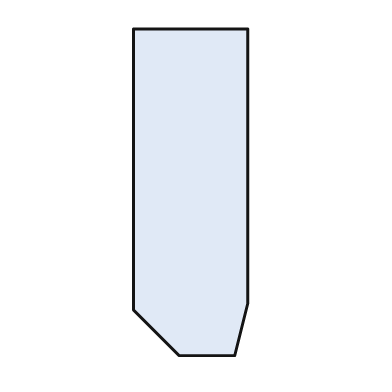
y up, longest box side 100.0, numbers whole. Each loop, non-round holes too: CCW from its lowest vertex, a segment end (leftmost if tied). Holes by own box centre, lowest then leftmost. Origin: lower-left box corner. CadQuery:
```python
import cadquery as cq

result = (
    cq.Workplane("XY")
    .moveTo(14.0, 0.0)
    .lineTo(31.0, 0.0)
    .lineTo(35.0, 16.0)
    .lineTo(35.0, 100.0)
    .lineTo(0.0, 100.0)
    .lineTo(0.0, 14.0)
    .close()
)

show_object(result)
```